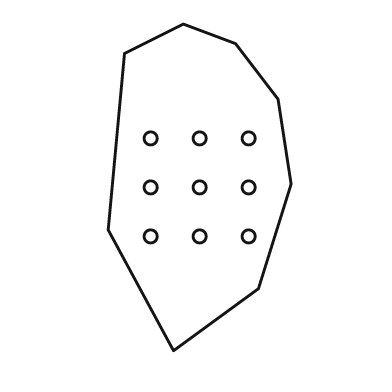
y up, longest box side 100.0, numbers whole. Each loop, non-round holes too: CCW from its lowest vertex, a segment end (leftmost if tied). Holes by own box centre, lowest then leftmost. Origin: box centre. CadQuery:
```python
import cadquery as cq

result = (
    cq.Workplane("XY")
    .moveTo(-8.0, -50.0)
    .lineTo(18.0, -31.0)
    .lineTo(28.0, 1.0)
    .lineTo(24.0, 27.0)
    .lineTo(11.0, 44.0)
    .lineTo(-5.0, 50.0)
    .lineTo(-23.0, 41.0)
    .lineTo(-28.0, -13.0)
    .close()
    .moveTo(-15.0, -15.0)
    .circle(2.0)
    .moveTo(0.0, -15.0)
    .circle(2.0)
    .moveTo(15.0, -15.0)
    .circle(2.0)
    .moveTo(-15.0, 0.0)
    .circle(2.0)
    .moveTo(0.0, 0.0)
    .circle(2.0)
    .moveTo(15.0, 0.0)
    .circle(2.0)
    .moveTo(-15.0, 15.0)
    .circle(2.0)
    .moveTo(0.0, 15.0)
    .circle(2.0)
    .moveTo(15.0, 15.0)
    .circle(2.0)
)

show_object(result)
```